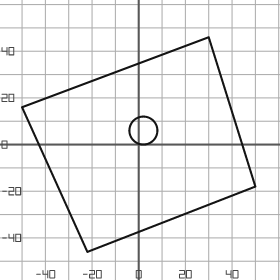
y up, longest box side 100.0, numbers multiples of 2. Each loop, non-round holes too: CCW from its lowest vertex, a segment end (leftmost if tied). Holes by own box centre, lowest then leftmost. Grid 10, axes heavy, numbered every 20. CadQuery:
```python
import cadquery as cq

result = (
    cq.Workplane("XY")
    .moveTo(-22.0, -46.0)
    .lineTo(50.0, -18.0)
    .lineTo(30.0, 46.0)
    .lineTo(-50.0, 16.0)
    .close()
    .moveTo(2.0, 6.0)
    .circle(6.0)
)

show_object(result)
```